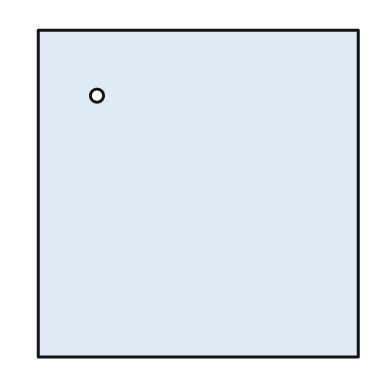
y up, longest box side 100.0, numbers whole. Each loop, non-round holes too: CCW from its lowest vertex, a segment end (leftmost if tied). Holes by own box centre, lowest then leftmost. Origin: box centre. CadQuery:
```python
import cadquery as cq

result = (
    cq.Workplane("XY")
    .moveTo(-49.0, -50.0)
    .lineTo(49.0, -50.0)
    .lineTo(49.0, 50.0)
    .lineTo(-49.0, 50.0)
    .close()
    .moveTo(-31.0, 30.0)
    .circle(2.0)
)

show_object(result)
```